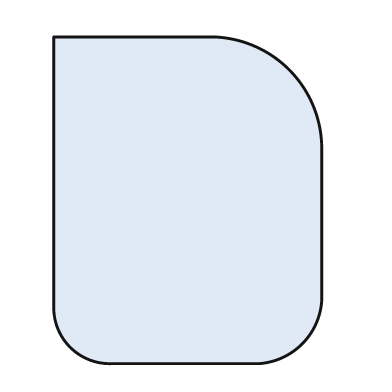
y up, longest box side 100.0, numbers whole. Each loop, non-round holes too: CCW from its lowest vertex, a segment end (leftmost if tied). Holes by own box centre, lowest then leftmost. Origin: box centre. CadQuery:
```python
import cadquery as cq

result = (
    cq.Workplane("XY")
    .moveTo(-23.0, -50.0)
    .lineTo(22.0, -50.0)
    .threePointArc((35.0, -44.0), (41.0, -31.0))
    .lineTo(41.0, 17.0)
    .threePointArc((31.0, 40.0), (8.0, 50.0))
    .lineTo(-41.0, 50.0)
    .lineTo(-41.0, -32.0)
    .threePointArc((-36.0, -45.0), (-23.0, -50.0))
    .close()
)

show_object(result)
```